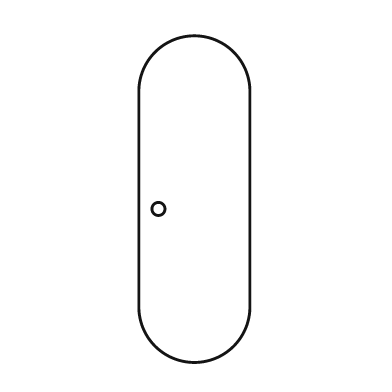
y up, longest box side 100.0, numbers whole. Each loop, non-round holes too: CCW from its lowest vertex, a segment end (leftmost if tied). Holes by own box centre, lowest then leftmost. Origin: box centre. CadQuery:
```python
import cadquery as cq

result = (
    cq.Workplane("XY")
    .moveTo(-17.0, -33.0)
    .threePointArc((0.0, -50.0), (17.0, -33.0))
    .lineTo(17.0, 33.0)
    .threePointArc((0.0, 50.0), (-17.0, 33.0))
    .close()
    .moveTo(-11.0, -3.0)
    .circle(2.0)
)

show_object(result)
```